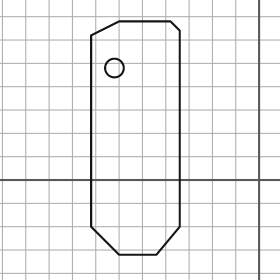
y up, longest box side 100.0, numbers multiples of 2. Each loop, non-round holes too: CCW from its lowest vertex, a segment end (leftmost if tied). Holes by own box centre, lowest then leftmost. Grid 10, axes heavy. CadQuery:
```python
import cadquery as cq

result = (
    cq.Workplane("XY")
    .moveTo(-60.0, -32.0)
    .lineTo(-44.0, -32.0)
    .lineTo(-34.0, -20.0)
    .lineTo(-34.0, 64.0)
    .lineTo(-38.0, 68.0)
    .lineTo(-60.0, 68.0)
    .lineTo(-72.0, 62.0)
    .lineTo(-72.0, -20.0)
    .close()
    .moveTo(-62.0, 48.0)
    .circle(4.0)
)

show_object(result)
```